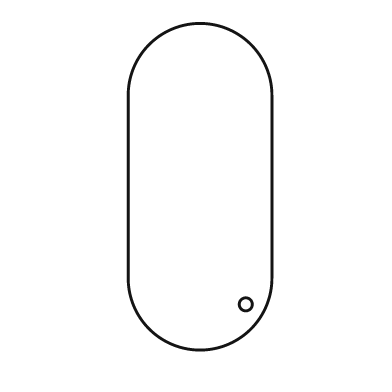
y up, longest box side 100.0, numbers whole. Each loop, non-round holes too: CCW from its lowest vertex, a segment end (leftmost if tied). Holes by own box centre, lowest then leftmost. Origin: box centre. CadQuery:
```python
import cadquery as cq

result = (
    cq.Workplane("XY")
    .moveTo(-22.0, -28.0)
    .threePointArc((0.0, -50.0), (22.0, -28.0))
    .lineTo(22.0, 28.0)
    .threePointArc((0.0, 50.0), (-22.0, 28.0))
    .close()
    .moveTo(14.0, -36.0)
    .circle(2.0)
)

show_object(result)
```